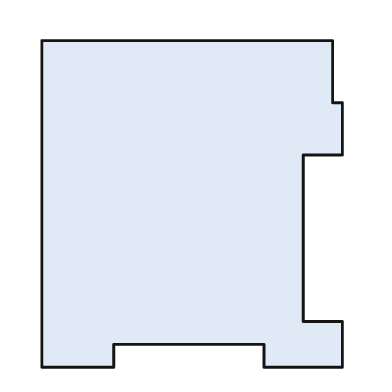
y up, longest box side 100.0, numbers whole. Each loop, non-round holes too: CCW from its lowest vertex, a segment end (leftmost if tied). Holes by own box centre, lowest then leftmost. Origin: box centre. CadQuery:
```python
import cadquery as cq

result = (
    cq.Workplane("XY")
    .moveTo(-46.0, -50.0)
    .lineTo(-24.0, -50.0)
    .lineTo(-24.0, -43.0)
    .lineTo(22.0, -43.0)
    .lineTo(22.0, -50.0)
    .lineTo(46.0, -50.0)
    .lineTo(46.0, -36.0)
    .lineTo(34.0, -36.0)
    .lineTo(34.0, 15.0)
    .lineTo(46.0, 15.0)
    .lineTo(46.0, 31.0)
    .lineTo(43.0, 31.0)
    .lineTo(43.0, 50.0)
    .lineTo(-46.0, 50.0)
    .close()
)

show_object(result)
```